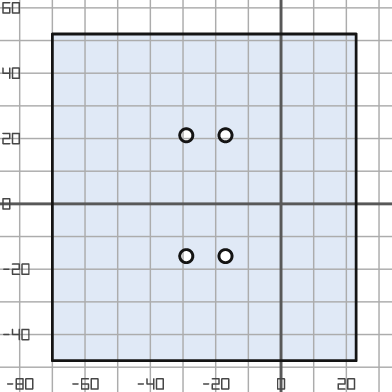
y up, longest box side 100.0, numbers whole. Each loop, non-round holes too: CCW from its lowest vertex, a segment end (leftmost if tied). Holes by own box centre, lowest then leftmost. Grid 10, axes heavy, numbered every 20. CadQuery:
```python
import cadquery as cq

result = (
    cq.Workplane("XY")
    .moveTo(-70.0, -48.0)
    .lineTo(23.0, -48.0)
    .lineTo(23.0, 52.0)
    .lineTo(-70.0, 52.0)
    .close()
    .moveTo(-29.0, -16.0)
    .circle(2.0)
    .moveTo(-17.0, -16.0)
    .circle(2.0)
    .moveTo(-29.0, 21.0)
    .circle(2.0)
    .moveTo(-17.0, 21.0)
    .circle(2.0)
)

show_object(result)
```